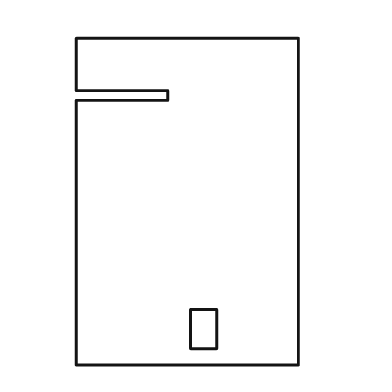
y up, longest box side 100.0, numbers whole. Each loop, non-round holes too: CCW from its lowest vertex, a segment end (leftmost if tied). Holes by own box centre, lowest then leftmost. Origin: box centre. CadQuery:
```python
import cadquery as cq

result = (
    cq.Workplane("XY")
    .moveTo(-34.0, -50.0)
    .lineTo(34.0, -50.0)
    .lineTo(34.0, 50.0)
    .lineTo(-34.0, 50.0)
    .lineTo(-34.0, 34.0)
    .lineTo(-6.0, 34.0)
    .lineTo(-6.0, 31.0)
    .lineTo(-34.0, 31.0)
    .close()
    .moveTo(1.0, -45.0)
    .lineTo(9.0, -45.0)
    .lineTo(9.0, -33.0)
    .lineTo(1.0, -33.0)
    .close()
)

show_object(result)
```